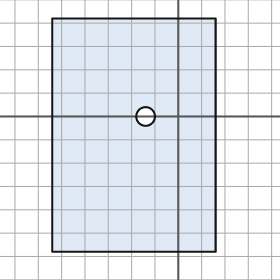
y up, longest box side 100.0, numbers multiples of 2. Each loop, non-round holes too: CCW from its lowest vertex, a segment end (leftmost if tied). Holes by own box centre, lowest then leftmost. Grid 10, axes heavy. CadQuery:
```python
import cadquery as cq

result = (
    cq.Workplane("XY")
    .moveTo(-54.0, -58.0)
    .lineTo(16.0, -58.0)
    .lineTo(16.0, 42.0)
    .lineTo(-54.0, 42.0)
    .close()
    .moveTo(-14.0, 0.0)
    .circle(4.0)
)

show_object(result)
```